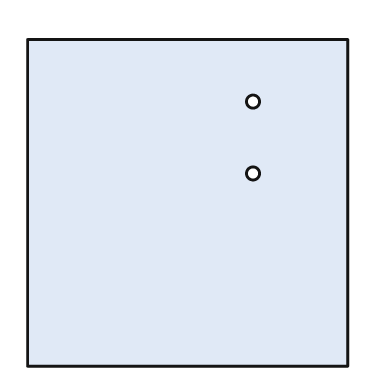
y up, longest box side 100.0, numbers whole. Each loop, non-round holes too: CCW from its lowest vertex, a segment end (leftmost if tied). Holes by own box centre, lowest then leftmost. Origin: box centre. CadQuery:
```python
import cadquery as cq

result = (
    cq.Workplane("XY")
    .moveTo(-49.0, -50.0)
    .lineTo(49.0, -50.0)
    .lineTo(49.0, 50.0)
    .lineTo(-49.0, 50.0)
    .close()
    .moveTo(20.0, 9.0)
    .circle(2.0)
    .moveTo(20.0, 31.0)
    .circle(2.0)
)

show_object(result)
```